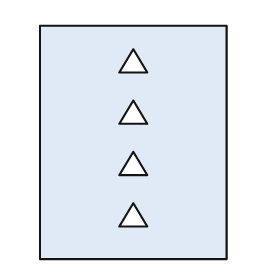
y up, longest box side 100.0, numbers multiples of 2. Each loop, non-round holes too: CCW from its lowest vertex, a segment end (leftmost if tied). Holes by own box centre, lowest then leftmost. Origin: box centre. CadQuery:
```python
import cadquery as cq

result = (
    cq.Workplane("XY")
    .moveTo(-40.0, -50.0)
    .lineTo(40.0, -50.0)
    .lineTo(40.0, 50.0)
    .lineTo(-40.0, 50.0)
    .close()
    .moveTo(-6.0, -36.0)
    .lineTo(6.0, -36.0)
    .lineTo(0.0, -26.0)
    .close()
    .moveTo(-6.0, -14.0)
    .lineTo(6.0, -14.0)
    .lineTo(0.0, -4.0)
    .close()
    .moveTo(-6.0, 8.0)
    .lineTo(6.0, 8.0)
    .lineTo(0.0, 18.0)
    .close()
    .moveTo(-6.0, 30.0)
    .lineTo(6.0, 30.0)
    .lineTo(0.0, 40.0)
    .close()
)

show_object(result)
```